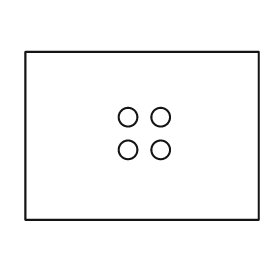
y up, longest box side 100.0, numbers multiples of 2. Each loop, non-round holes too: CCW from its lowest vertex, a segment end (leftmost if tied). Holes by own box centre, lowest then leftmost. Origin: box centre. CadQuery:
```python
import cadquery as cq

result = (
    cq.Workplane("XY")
    .moveTo(-50.0, -36.0)
    .lineTo(50.0, -36.0)
    .lineTo(50.0, 36.0)
    .lineTo(-50.0, 36.0)
    .close()
    .moveTo(-6.0, -6.0)
    .circle(4.0)
    .moveTo(8.0, -6.0)
    .circle(4.0)
    .moveTo(-6.0, 8.0)
    .circle(4.0)
    .moveTo(8.0, 8.0)
    .circle(4.0)
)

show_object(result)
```